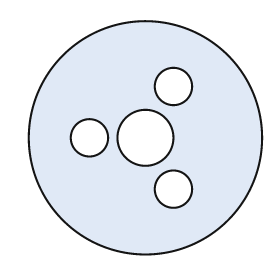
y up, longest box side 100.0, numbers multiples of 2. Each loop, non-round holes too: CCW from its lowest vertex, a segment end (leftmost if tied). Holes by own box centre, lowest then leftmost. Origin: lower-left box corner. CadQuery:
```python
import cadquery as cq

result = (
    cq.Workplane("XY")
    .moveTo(50.0, 50.0)
    .circle(50.0)
    .moveTo(62.0, 28.0)
    .circle(8.0)
    .moveTo(26.0, 50.0)
    .circle(8.0)
    .moveTo(50.0, 50.0)
    .circle(12.0)
    .moveTo(62.0, 72.0)
    .circle(8.0)
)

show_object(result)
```